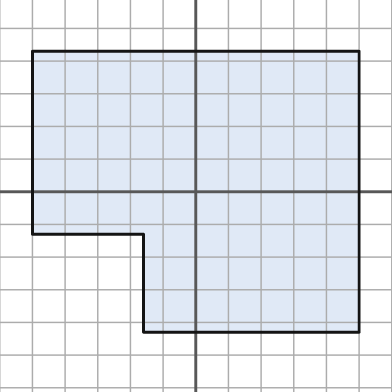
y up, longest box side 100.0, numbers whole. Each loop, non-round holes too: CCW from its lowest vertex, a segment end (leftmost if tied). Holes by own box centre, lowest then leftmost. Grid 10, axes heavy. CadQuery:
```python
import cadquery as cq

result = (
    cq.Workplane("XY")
    .moveTo(-16.0, -43.0)
    .lineTo(50.0, -43.0)
    .lineTo(50.0, 43.0)
    .lineTo(-50.0, 43.0)
    .lineTo(-50.0, -13.0)
    .lineTo(-16.0, -13.0)
    .close()
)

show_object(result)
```